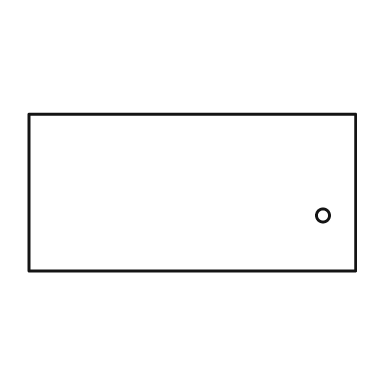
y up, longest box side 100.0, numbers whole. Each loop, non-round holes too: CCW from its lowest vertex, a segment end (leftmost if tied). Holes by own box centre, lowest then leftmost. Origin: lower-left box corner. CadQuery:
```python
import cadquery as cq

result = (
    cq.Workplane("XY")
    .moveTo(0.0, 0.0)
    .lineTo(100.0, 0.0)
    .lineTo(100.0, 48.0)
    .lineTo(0.0, 48.0)
    .close()
    .moveTo(90.0, 17.0)
    .circle(2.0)
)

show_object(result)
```